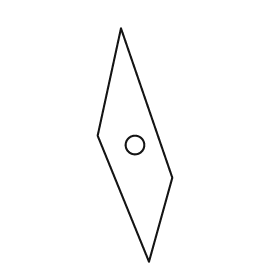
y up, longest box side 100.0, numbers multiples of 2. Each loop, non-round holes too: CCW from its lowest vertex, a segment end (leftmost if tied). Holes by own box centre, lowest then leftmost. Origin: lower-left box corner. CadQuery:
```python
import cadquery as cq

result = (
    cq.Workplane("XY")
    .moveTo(22.0, 0.0)
    .lineTo(32.0, 36.0)
    .lineTo(10.0, 100.0)
    .lineTo(0.0, 54.0)
    .close()
    .moveTo(16.0, 50.0)
    .circle(4.0)
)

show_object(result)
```